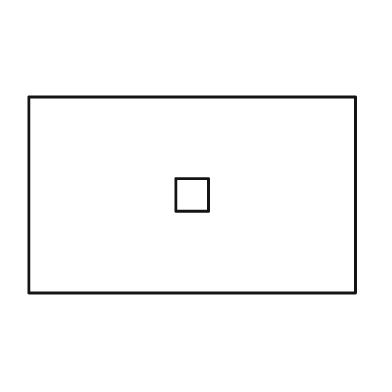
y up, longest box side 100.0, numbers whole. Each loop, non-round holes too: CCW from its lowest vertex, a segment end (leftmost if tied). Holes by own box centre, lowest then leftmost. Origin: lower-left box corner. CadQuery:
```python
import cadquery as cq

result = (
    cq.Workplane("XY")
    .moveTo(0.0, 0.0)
    .lineTo(100.0, 0.0)
    .lineTo(100.0, 60.0)
    .lineTo(0.0, 60.0)
    .close()
    .moveTo(45.0, 25.0)
    .lineTo(55.0, 25.0)
    .lineTo(55.0, 35.0)
    .lineTo(45.0, 35.0)
    .close()
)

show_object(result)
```